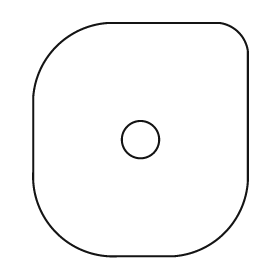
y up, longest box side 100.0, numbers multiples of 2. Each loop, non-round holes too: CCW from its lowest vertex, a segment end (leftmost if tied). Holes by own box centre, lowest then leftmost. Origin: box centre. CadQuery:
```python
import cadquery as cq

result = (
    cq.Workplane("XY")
    .moveTo(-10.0, -50.0)
    .lineTo(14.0, -50.0)
    .threePointArc((36.0, -40.0), (46.0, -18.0))
    .lineTo(46.0, 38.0)
    .threePointArc((42.0, 46.0), (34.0, 50.0))
    .lineTo(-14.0, 50.0)
    .threePointArc((-36.0, 40.0), (-46.0, 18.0))
    .lineTo(-46.0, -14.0)
    .threePointArc((-36.0, -40.0), (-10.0, -50.0))
    .close()
    .moveTo(0.0, 0.0)
    .circle(8.0)
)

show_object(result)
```